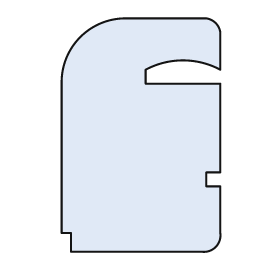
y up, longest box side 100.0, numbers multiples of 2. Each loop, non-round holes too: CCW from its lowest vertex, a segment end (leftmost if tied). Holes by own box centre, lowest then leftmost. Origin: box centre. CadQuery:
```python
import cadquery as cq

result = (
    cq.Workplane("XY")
    .moveTo(-30.0, -50.0)
    .lineTo(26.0, -50.0)
    .threePointArc((32.0, -48.0), (34.0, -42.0))
    .lineTo(34.0, -22.0)
    .lineTo(28.0, -22.0)
    .lineTo(28.0, -16.0)
    .lineTo(34.0, -16.0)
    .lineTo(34.0, 22.0)
    .lineTo(2.0, 22.0)
    .lineTo(2.0, 28.0)
    .threePointArc((18.0, 32.0), (34.0, 28.0))
    .lineTo(34.0, 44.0)
    .threePointArc((32.0, 48.0), (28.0, 50.0))
    .lineTo(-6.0, 50.0)
    .threePointArc((-26.0, 42.0), (-34.0, 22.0))
    .lineTo(-34.0, -42.0)
    .lineTo(-30.0, -42.0)
    .close()
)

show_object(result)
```